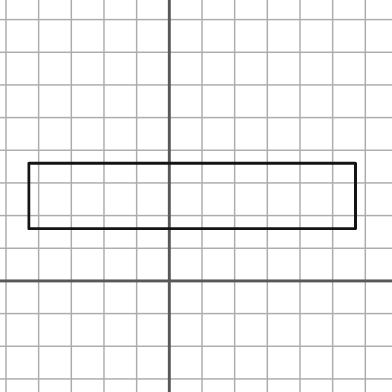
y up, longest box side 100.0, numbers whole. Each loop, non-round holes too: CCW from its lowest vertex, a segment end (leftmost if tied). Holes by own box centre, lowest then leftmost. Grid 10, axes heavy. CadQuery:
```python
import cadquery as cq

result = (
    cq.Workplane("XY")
    .moveTo(-43.0, 16.0)
    .lineTo(57.0, 16.0)
    .lineTo(57.0, 36.0)
    .lineTo(-43.0, 36.0)
    .close()
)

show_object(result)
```